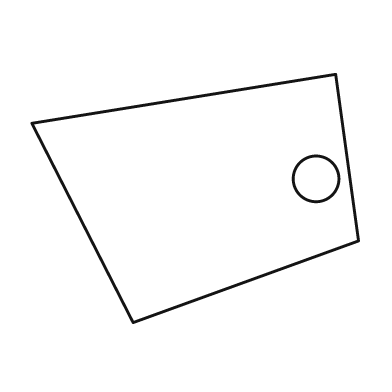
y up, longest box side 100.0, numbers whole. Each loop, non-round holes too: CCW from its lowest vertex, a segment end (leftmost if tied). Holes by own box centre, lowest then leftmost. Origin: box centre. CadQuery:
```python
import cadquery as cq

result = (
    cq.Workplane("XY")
    .moveTo(-19.0, -38.0)
    .lineTo(50.0, -13.0)
    .lineTo(43.0, 38.0)
    .lineTo(-50.0, 23.0)
    .close()
    .moveTo(37.0, 6.0)
    .circle(7.0)
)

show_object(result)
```